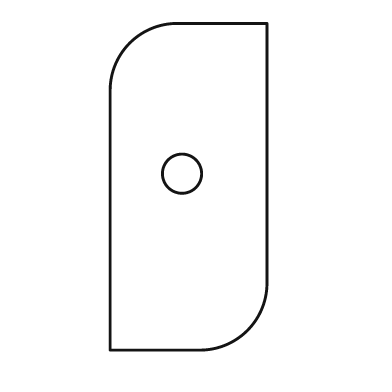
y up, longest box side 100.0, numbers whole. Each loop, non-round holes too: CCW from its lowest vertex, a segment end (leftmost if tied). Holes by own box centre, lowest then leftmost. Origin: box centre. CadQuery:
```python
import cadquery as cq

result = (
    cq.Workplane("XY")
    .moveTo(-24.0, -50.0)
    .lineTo(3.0, -50.0)
    .threePointArc((18.0, -44.0), (24.0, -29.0))
    .lineTo(24.0, 50.0)
    .lineTo(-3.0, 50.0)
    .threePointArc((-18.0, 44.0), (-24.0, 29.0))
    .close()
    .moveTo(-2.0, 4.0)
    .circle(6.0)
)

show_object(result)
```